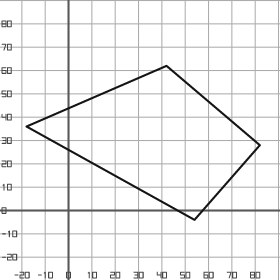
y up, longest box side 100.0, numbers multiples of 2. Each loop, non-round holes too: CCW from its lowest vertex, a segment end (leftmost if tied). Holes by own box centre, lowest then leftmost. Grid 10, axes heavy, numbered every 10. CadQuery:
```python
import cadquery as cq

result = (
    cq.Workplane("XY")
    .moveTo(54.0, -4.0)
    .lineTo(82.0, 28.0)
    .lineTo(42.0, 62.0)
    .lineTo(-18.0, 36.0)
    .close()
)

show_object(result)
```